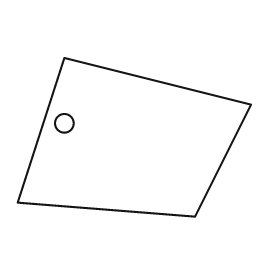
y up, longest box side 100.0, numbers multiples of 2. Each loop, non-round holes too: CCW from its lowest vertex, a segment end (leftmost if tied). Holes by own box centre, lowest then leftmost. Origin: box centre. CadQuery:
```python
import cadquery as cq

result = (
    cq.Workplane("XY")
    .moveTo(26.0, -34.0)
    .lineTo(50.0, 14.0)
    .lineTo(-30.0, 34.0)
    .lineTo(-50.0, -28.0)
    .close()
    .moveTo(-30.0, 6.0)
    .circle(4.0)
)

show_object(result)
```